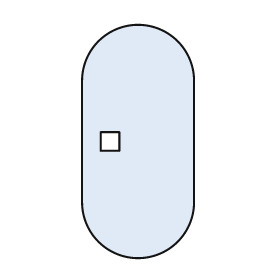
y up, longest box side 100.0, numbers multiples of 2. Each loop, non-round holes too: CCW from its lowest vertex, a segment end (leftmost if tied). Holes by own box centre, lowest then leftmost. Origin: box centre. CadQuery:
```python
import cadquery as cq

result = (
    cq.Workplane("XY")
    .moveTo(-24.0, -26.0)
    .threePointArc((0.0, -50.0), (24.0, -26.0))
    .lineTo(24.0, 26.0)
    .threePointArc((0.0, 50.0), (-24.0, 26.0))
    .close()
    .moveTo(-16.0, -4.0)
    .lineTo(-8.0, -4.0)
    .lineTo(-8.0, 4.0)
    .lineTo(-16.0, 4.0)
    .close()
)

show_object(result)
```